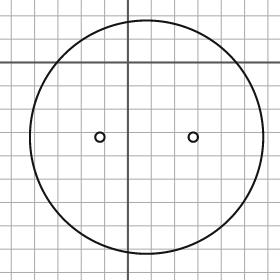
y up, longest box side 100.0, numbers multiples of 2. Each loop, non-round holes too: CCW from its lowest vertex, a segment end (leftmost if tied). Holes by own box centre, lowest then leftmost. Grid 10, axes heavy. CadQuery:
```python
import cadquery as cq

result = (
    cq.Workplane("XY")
    .moveTo(8.0, -32.0)
    .circle(50.0)
    .moveTo(-12.0, -32.0)
    .circle(2.0)
    .moveTo(28.0, -32.0)
    .circle(2.0)
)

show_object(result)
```